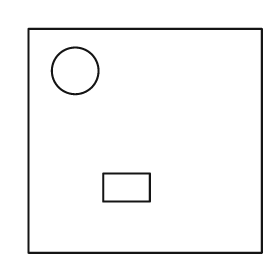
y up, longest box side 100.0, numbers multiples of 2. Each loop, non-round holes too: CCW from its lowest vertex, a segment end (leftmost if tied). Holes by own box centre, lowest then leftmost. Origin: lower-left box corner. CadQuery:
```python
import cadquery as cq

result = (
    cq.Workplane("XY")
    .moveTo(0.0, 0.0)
    .lineTo(100.0, 0.0)
    .lineTo(100.0, 96.0)
    .lineTo(0.0, 96.0)
    .close()
    .moveTo(32.0, 22.0)
    .lineTo(52.0, 22.0)
    .lineTo(52.0, 34.0)
    .lineTo(32.0, 34.0)
    .close()
    .moveTo(20.0, 78.0)
    .circle(10.0)
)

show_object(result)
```